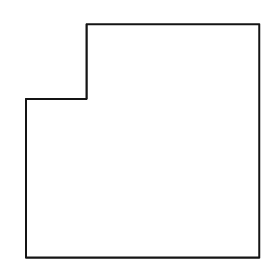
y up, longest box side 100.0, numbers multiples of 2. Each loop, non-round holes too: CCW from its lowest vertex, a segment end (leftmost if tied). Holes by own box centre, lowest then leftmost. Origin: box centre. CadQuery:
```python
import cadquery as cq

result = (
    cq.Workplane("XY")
    .moveTo(-50.0, -50.0)
    .lineTo(50.0, -50.0)
    .lineTo(50.0, 50.0)
    .lineTo(-24.0, 50.0)
    .lineTo(-24.0, 18.0)
    .lineTo(-50.0, 18.0)
    .close()
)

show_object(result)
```